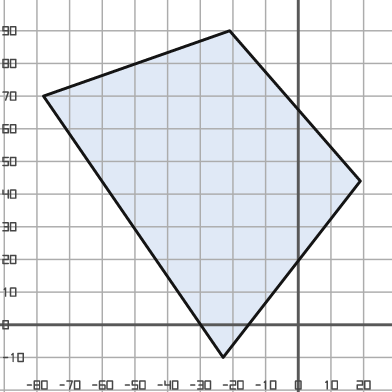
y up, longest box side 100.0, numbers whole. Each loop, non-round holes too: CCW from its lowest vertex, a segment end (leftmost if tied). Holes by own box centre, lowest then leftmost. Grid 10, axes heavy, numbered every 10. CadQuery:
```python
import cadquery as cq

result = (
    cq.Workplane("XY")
    .moveTo(-23.0, -10.0)
    .lineTo(19.0, 44.0)
    .lineTo(-21.0, 90.0)
    .lineTo(-78.0, 70.0)
    .close()
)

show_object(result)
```